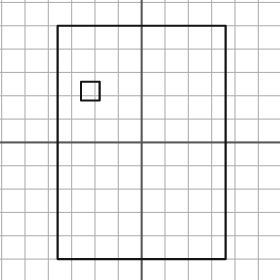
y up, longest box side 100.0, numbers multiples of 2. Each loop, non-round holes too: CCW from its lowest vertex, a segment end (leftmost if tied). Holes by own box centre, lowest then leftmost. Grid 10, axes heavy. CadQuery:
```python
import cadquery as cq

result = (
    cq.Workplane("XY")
    .moveTo(-36.0, -50.0)
    .lineTo(36.0, -50.0)
    .lineTo(36.0, 50.0)
    .lineTo(-36.0, 50.0)
    .close()
    .moveTo(-26.0, 18.0)
    .lineTo(-18.0, 18.0)
    .lineTo(-18.0, 26.0)
    .lineTo(-26.0, 26.0)
    .close()
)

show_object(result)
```